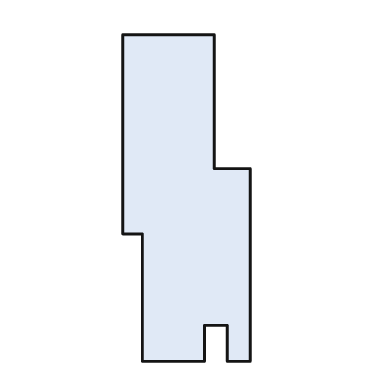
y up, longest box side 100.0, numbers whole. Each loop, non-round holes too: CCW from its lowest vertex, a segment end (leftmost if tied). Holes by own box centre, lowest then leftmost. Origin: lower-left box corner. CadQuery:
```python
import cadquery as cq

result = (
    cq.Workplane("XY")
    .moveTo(6.0, 0.0)
    .lineTo(25.0, 0.0)
    .lineTo(25.0, 11.0)
    .lineTo(32.0, 11.0)
    .lineTo(32.0, 0.0)
    .lineTo(39.0, 0.0)
    .lineTo(39.0, 59.0)
    .lineTo(28.0, 59.0)
    .lineTo(28.0, 100.0)
    .lineTo(0.0, 100.0)
    .lineTo(0.0, 39.0)
    .lineTo(6.0, 39.0)
    .close()
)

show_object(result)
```